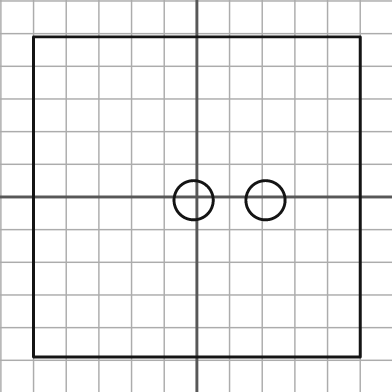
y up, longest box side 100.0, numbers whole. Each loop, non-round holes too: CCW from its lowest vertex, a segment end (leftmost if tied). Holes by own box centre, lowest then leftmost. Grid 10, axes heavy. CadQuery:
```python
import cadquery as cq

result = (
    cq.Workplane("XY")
    .moveTo(-50.0, -49.0)
    .lineTo(50.0, -49.0)
    .lineTo(50.0, 49.0)
    .lineTo(-50.0, 49.0)
    .close()
    .moveTo(-1.0, -1.0)
    .circle(6.0)
    .moveTo(21.0, -1.0)
    .circle(6.0)
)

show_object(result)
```